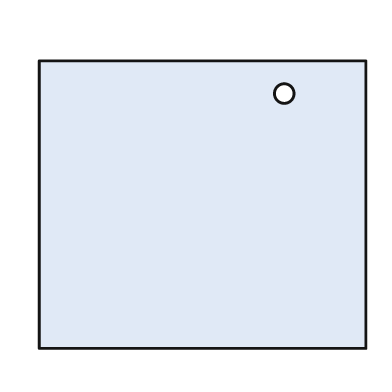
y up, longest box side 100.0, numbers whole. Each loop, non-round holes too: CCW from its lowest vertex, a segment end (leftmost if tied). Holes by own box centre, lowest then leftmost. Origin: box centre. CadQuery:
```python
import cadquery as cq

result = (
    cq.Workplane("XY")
    .moveTo(-50.0, -44.0)
    .lineTo(50.0, -44.0)
    .lineTo(50.0, 44.0)
    .lineTo(-50.0, 44.0)
    .close()
    .moveTo(25.0, 34.0)
    .circle(3.0)
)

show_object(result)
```